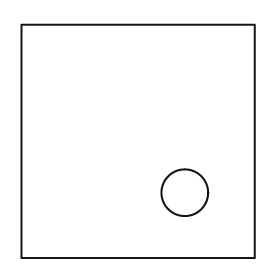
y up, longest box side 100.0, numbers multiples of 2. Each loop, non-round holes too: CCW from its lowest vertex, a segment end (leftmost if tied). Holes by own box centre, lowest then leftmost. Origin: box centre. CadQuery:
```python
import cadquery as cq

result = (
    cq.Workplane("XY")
    .moveTo(-50.0, -50.0)
    .lineTo(50.0, -50.0)
    .lineTo(50.0, 50.0)
    .lineTo(-50.0, 50.0)
    .close()
    .moveTo(20.0, -22.0)
    .circle(10.0)
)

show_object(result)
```